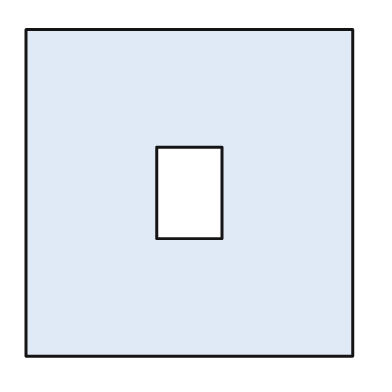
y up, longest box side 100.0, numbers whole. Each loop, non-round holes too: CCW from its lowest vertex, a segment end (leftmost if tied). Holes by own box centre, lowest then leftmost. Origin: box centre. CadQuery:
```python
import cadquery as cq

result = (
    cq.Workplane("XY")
    .moveTo(-50.0, -50.0)
    .lineTo(50.0, -50.0)
    .lineTo(50.0, 50.0)
    .lineTo(-50.0, 50.0)
    .close()
    .moveTo(-10.0, -14.0)
    .lineTo(10.0, -14.0)
    .lineTo(10.0, 14.0)
    .lineTo(-10.0, 14.0)
    .close()
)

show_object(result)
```